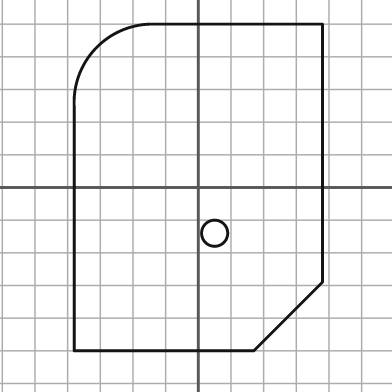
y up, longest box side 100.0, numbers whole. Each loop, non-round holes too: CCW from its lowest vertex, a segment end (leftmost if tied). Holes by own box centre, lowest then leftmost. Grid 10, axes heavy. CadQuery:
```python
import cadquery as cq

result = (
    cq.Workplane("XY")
    .moveTo(-38.0, -50.0)
    .lineTo(17.0, -50.0)
    .lineTo(38.0, -29.0)
    .lineTo(38.0, 50.0)
    .lineTo(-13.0, 50.0)
    .threePointArc((-31.0, 43.0), (-38.0, 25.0))
    .close()
    .moveTo(5.0, -14.0)
    .circle(4.0)
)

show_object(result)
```